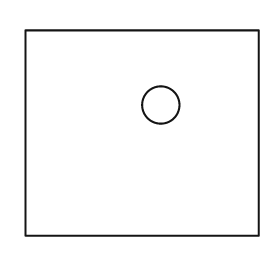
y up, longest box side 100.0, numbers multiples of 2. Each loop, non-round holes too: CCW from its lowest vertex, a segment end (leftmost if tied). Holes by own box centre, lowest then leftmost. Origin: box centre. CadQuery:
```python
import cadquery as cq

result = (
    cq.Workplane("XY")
    .moveTo(-50.0, -44.0)
    .lineTo(50.0, -44.0)
    .lineTo(50.0, 44.0)
    .lineTo(-50.0, 44.0)
    .close()
    .moveTo(8.0, 12.0)
    .circle(8.0)
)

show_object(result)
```